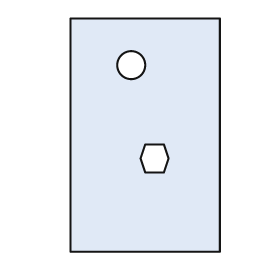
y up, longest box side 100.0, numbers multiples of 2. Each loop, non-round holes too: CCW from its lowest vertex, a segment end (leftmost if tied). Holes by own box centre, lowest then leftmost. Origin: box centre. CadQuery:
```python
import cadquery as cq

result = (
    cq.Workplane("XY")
    .moveTo(-32.0, -50.0)
    .lineTo(32.0, -50.0)
    .lineTo(32.0, 50.0)
    .lineTo(-32.0, 50.0)
    .close()
    .moveTo(0.0, -16.0)
    .lineTo(8.0, -16.0)
    .lineTo(10.0, -10.0)
    .lineTo(8.0, -4.0)
    .lineTo(0.0, -4.0)
    .lineTo(-2.0, -10.0)
    .close()
    .moveTo(-6.0, 30.0)
    .circle(6.0)
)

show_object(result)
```